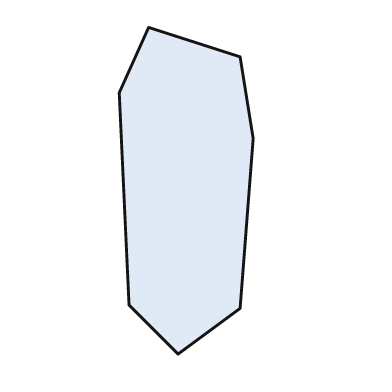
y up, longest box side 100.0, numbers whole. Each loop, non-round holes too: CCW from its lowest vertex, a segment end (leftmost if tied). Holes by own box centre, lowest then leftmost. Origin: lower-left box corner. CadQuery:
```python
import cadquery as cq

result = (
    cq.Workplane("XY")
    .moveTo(18.0, 0.0)
    .lineTo(37.0, 14.0)
    .lineTo(41.0, 66.0)
    .lineTo(37.0, 91.0)
    .lineTo(9.0, 100.0)
    .lineTo(0.0, 80.0)
    .lineTo(3.0, 15.0)
    .close()
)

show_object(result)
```